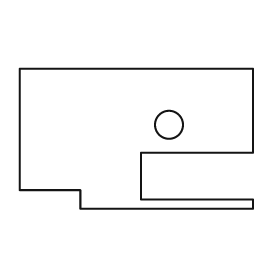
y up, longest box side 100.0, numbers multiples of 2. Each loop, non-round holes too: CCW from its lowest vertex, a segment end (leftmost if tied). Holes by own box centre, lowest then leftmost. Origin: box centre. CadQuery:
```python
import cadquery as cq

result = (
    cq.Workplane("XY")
    .moveTo(-24.0, -30.0)
    .lineTo(50.0, -30.0)
    .lineTo(50.0, -26.0)
    .lineTo(2.0, -26.0)
    .lineTo(2.0, -6.0)
    .lineTo(50.0, -6.0)
    .lineTo(50.0, 30.0)
    .lineTo(-50.0, 30.0)
    .lineTo(-50.0, -22.0)
    .lineTo(-24.0, -22.0)
    .close()
    .moveTo(14.0, 6.0)
    .circle(6.0)
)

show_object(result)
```